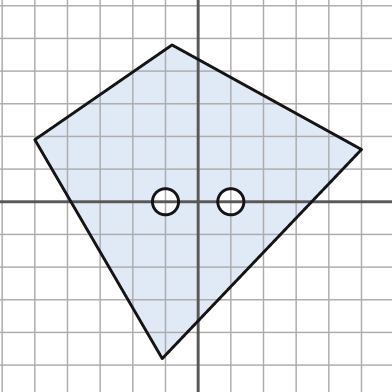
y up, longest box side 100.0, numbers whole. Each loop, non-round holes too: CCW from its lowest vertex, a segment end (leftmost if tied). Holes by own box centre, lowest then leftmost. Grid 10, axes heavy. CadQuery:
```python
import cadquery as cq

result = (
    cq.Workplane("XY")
    .moveTo(-11.0, -48.0)
    .lineTo(50.0, 16.0)
    .lineTo(-8.0, 48.0)
    .lineTo(-50.0, 19.0)
    .close()
    .moveTo(-10.0, 0.0)
    .circle(4.0)
    .moveTo(10.0, 0.0)
    .circle(4.0)
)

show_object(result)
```